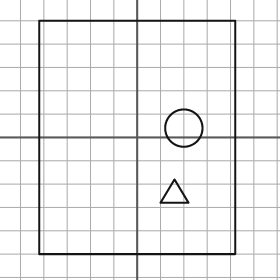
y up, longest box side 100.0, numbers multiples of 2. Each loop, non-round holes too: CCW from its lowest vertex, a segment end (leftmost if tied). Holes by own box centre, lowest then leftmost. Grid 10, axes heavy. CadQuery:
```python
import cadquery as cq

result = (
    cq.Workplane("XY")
    .moveTo(-42.0, -50.0)
    .lineTo(42.0, -50.0)
    .lineTo(42.0, 50.0)
    .lineTo(-42.0, 50.0)
    .close()
    .moveTo(10.0, -28.0)
    .lineTo(22.0, -28.0)
    .lineTo(16.0, -18.0)
    .close()
    .moveTo(20.0, 4.0)
    .circle(8.0)
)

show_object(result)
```